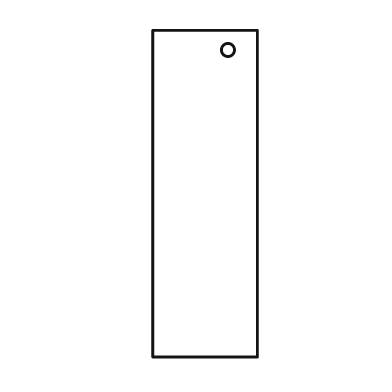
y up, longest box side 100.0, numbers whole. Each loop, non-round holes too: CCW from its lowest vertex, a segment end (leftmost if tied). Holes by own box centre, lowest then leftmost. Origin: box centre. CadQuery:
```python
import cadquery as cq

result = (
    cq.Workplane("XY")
    .moveTo(-16.0, -50.0)
    .lineTo(16.0, -50.0)
    .lineTo(16.0, 50.0)
    .lineTo(-16.0, 50.0)
    .close()
    .moveTo(7.0, 44.0)
    .circle(2.0)
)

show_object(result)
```